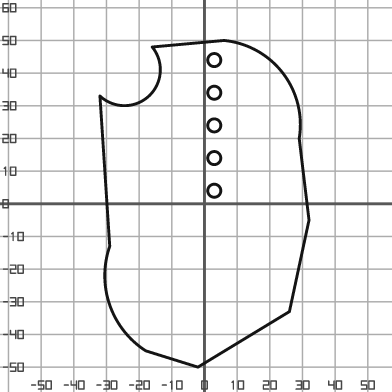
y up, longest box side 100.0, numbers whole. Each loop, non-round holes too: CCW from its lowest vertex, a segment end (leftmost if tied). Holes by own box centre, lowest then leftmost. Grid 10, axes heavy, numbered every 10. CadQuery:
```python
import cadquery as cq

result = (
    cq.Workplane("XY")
    .moveTo(-2.0, -50.0)
    .lineTo(26.0, -33.0)
    .lineTo(32.0, -5.0)
    .lineTo(29.0, 20.0)
    .threePointArc((24.0, 40.0), (6.0, 50.0))
    .lineTo(-16.0, 48.0)
    .threePointArc((-17.0, 33.0), (-32.0, 33.0))
    .lineTo(-29.0, -13.0)
    .threePointArc((-29.0, -31.0), (-18.0, -45.0))
    .close()
    .moveTo(3.0, 4.0)
    .circle(2.0)
    .moveTo(3.0, 14.0)
    .circle(2.0)
    .moveTo(3.0, 24.0)
    .circle(2.0)
    .moveTo(3.0, 34.0)
    .circle(2.0)
    .moveTo(3.0, 44.0)
    .circle(2.0)
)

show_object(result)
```